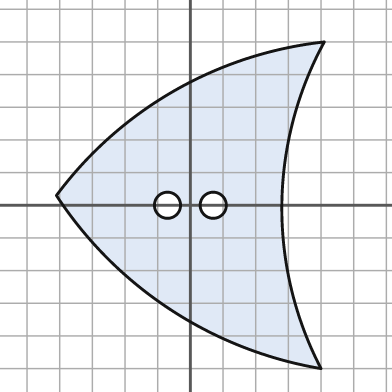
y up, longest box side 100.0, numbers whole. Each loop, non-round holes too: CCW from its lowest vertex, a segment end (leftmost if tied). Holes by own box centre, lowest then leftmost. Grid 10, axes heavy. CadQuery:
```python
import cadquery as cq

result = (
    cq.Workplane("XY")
    .moveTo(40.0, -50.0)
    .threePointArc((28.0, 0.0), (41.0, 50.0))
    .threePointArc((-5.0, 35.0), (-41.0, 3.0))
    .threePointArc((-6.0, -32.0), (40.0, -50.0))
    .close()
    .moveTo(-7.0, 0.0)
    .circle(4.0)
    .moveTo(7.0, 0.0)
    .circle(4.0)
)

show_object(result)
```